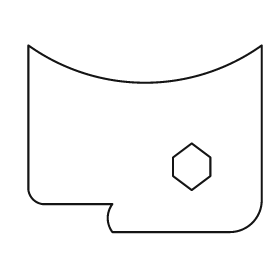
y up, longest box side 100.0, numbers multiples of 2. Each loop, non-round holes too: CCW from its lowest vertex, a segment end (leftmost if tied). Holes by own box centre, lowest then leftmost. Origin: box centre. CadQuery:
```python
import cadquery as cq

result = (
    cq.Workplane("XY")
    .moveTo(-14.0, -40.0)
    .lineTo(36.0, -40.0)
    .threePointArc((46.0, -36.0), (50.0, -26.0))
    .lineTo(50.0, 40.0)
    .threePointArc((0.0, 24.0), (-50.0, 40.0))
    .lineTo(-50.0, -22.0)
    .threePointArc((-48.0, -26.0), (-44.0, -28.0))
    .lineTo(-14.0, -28.0)
    .threePointArc((-16.0, -34.0), (-14.0, -40.0))
    .close()
    .moveTo(20.0, -22.0)
    .lineTo(28.0, -16.0)
    .lineTo(28.0, -8.0)
    .lineTo(20.0, -2.0)
    .lineTo(12.0, -8.0)
    .lineTo(12.0, -16.0)
    .close()
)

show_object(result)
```